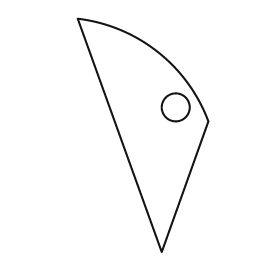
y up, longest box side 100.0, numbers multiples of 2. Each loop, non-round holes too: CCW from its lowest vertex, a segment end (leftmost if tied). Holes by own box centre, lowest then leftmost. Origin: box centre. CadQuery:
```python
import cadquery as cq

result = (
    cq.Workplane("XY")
    .moveTo(8.0, -50.0)
    .lineTo(28.0, 6.0)
    .threePointArc((6.0, 36.0), (-28.0, 50.0))
    .close()
    .moveTo(14.0, 12.0)
    .circle(6.0)
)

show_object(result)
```